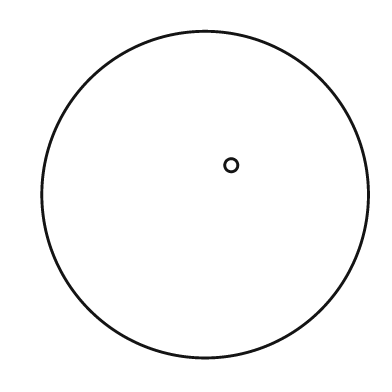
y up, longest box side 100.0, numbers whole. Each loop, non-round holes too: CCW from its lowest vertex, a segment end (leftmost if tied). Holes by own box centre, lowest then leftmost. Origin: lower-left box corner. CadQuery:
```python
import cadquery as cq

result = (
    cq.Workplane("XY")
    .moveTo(50.0, 50.0)
    .circle(50.0)
    .moveTo(58.0, 59.0)
    .circle(2.0)
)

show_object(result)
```